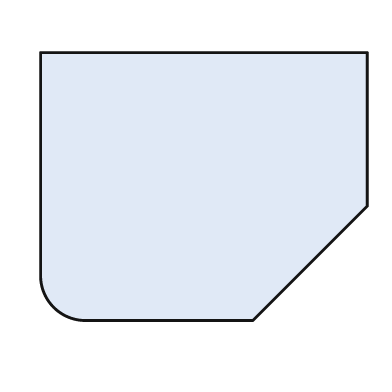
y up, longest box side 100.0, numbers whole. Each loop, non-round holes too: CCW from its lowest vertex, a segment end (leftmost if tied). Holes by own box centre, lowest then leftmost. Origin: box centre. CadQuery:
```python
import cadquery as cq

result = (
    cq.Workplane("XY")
    .moveTo(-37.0, -41.0)
    .lineTo(15.0, -41.0)
    .lineTo(50.0, -6.0)
    .lineTo(50.0, 41.0)
    .lineTo(-50.0, 41.0)
    .lineTo(-50.0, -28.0)
    .threePointArc((-46.0, -37.0), (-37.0, -41.0))
    .close()
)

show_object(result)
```